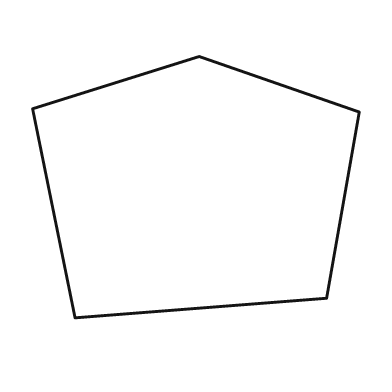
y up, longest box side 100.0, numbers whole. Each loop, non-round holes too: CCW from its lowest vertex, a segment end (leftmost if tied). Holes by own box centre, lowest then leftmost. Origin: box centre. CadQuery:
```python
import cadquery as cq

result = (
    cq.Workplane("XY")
    .moveTo(-37.0, -40.0)
    .lineTo(40.0, -34.0)
    .lineTo(50.0, 23.0)
    .lineTo(1.0, 40.0)
    .lineTo(-50.0, 24.0)
    .close()
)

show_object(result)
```